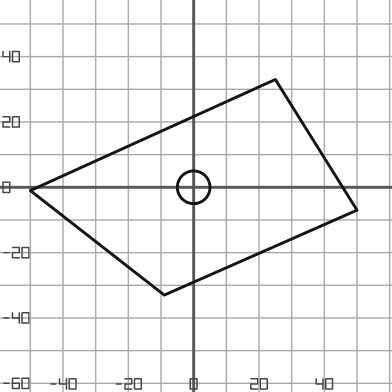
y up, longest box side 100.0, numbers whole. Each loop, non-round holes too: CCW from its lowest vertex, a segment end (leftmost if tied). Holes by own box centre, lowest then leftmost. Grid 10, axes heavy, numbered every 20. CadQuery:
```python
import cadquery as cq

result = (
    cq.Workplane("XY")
    .moveTo(-9.0, -33.0)
    .lineTo(50.0, -7.0)
    .lineTo(25.0, 33.0)
    .lineTo(-50.0, -1.0)
    .close()
    .moveTo(0.0, 0.0)
    .circle(5.0)
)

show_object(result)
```